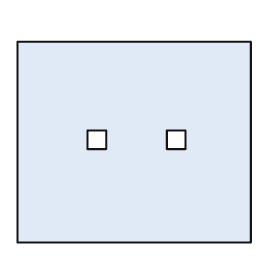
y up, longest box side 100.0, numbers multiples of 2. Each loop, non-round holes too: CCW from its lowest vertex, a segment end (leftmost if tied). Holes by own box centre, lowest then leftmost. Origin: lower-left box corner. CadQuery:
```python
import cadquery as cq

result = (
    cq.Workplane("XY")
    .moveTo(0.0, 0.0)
    .lineTo(100.0, 0.0)
    .lineTo(100.0, 86.0)
    .lineTo(0.0, 86.0)
    .close()
    .moveTo(30.0, 40.0)
    .lineTo(38.0, 40.0)
    .lineTo(38.0, 48.0)
    .lineTo(30.0, 48.0)
    .close()
    .moveTo(64.0, 40.0)
    .lineTo(72.0, 40.0)
    .lineTo(72.0, 48.0)
    .lineTo(64.0, 48.0)
    .close()
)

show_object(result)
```